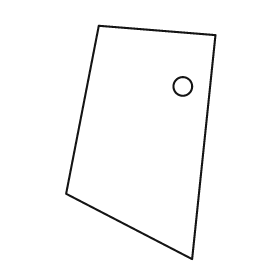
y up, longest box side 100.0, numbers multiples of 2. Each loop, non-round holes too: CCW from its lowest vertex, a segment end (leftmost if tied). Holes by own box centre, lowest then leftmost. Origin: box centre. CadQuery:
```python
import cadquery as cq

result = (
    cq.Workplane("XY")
    .moveTo(22.0, -50.0)
    .lineTo(32.0, 46.0)
    .lineTo(-18.0, 50.0)
    .lineTo(-32.0, -22.0)
    .close()
    .moveTo(18.0, 24.0)
    .circle(4.0)
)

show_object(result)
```